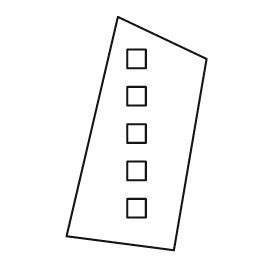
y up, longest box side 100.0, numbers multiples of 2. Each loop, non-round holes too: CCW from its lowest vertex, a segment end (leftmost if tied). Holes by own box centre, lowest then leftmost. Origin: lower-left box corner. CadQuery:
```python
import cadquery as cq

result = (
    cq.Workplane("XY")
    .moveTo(46.0, 0.0)
    .lineTo(60.0, 82.0)
    .lineTo(22.0, 100.0)
    .lineTo(0.0, 6.0)
    .close()
    .moveTo(26.0, 14.0)
    .lineTo(34.0, 14.0)
    .lineTo(34.0, 22.0)
    .lineTo(26.0, 22.0)
    .close()
    .moveTo(26.0, 30.0)
    .lineTo(34.0, 30.0)
    .lineTo(34.0, 38.0)
    .lineTo(26.0, 38.0)
    .close()
    .moveTo(26.0, 46.0)
    .lineTo(34.0, 46.0)
    .lineTo(34.0, 54.0)
    .lineTo(26.0, 54.0)
    .close()
    .moveTo(26.0, 62.0)
    .lineTo(34.0, 62.0)
    .lineTo(34.0, 70.0)
    .lineTo(26.0, 70.0)
    .close()
    .moveTo(26.0, 78.0)
    .lineTo(34.0, 78.0)
    .lineTo(34.0, 86.0)
    .lineTo(26.0, 86.0)
    .close()
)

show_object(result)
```